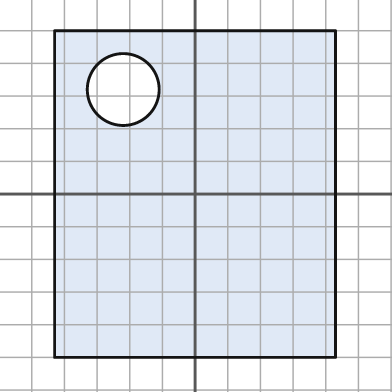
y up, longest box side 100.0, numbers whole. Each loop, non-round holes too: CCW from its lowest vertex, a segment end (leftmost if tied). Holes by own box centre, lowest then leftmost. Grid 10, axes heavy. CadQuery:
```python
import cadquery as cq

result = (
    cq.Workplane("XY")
    .moveTo(-43.0, -50.0)
    .lineTo(43.0, -50.0)
    .lineTo(43.0, 50.0)
    .lineTo(-43.0, 50.0)
    .close()
    .moveTo(-22.0, 32.0)
    .circle(11.0)
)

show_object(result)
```